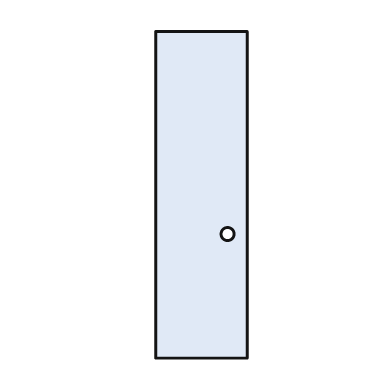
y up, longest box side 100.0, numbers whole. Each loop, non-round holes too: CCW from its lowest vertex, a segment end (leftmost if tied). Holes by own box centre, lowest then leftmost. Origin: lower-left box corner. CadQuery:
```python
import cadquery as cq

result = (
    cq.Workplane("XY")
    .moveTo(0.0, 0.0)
    .lineTo(28.0, 0.0)
    .lineTo(28.0, 100.0)
    .lineTo(0.0, 100.0)
    .close()
    .moveTo(22.0, 38.0)
    .circle(2.0)
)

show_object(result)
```